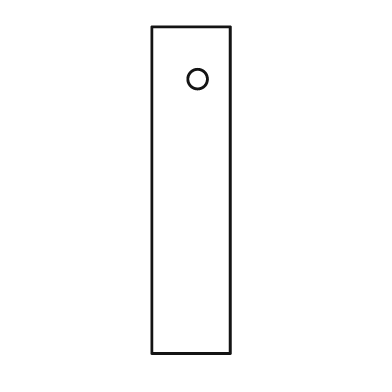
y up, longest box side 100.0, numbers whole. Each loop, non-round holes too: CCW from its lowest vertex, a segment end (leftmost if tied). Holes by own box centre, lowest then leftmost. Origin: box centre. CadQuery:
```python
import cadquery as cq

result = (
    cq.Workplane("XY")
    .moveTo(-12.0, -50.0)
    .lineTo(12.0, -50.0)
    .lineTo(12.0, 50.0)
    .lineTo(-12.0, 50.0)
    .close()
    .moveTo(2.0, 34.0)
    .circle(3.0)
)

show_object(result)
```